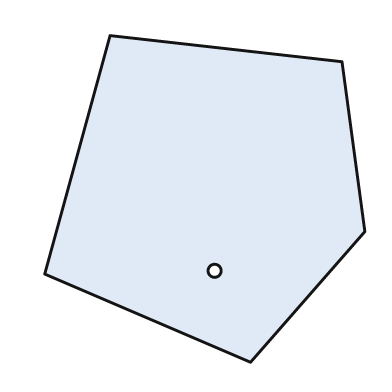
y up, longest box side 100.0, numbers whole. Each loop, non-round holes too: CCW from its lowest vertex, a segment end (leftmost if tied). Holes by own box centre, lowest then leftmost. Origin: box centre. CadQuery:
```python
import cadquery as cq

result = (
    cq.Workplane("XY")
    .moveTo(14.0, -50.0)
    .lineTo(49.0, -10.0)
    .lineTo(42.0, 42.0)
    .lineTo(-29.0, 50.0)
    .lineTo(-49.0, -23.0)
    .close()
    .moveTo(3.0, -22.0)
    .circle(2.0)
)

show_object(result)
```